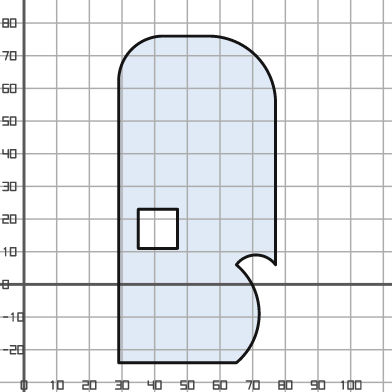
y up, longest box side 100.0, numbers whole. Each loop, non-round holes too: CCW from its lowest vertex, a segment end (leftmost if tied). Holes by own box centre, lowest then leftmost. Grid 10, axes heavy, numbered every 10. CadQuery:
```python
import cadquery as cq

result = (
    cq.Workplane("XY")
    .moveTo(29.0, -24.0)
    .lineTo(65.0, -24.0)
    .threePointArc((72.0, -9.0), (65.0, 6.0))
    .threePointArc((71.0, 9.0), (77.0, 6.0))
    .lineTo(77.0, 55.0)
    .threePointArc((71.0, 70.0), (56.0, 76.0))
    .lineTo(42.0, 76.0)
    .threePointArc((33.0, 72.0), (29.0, 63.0))
    .close()
    .moveTo(35.0, 11.0)
    .lineTo(47.0, 11.0)
    .lineTo(47.0, 23.0)
    .lineTo(35.0, 23.0)
    .close()
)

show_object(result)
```